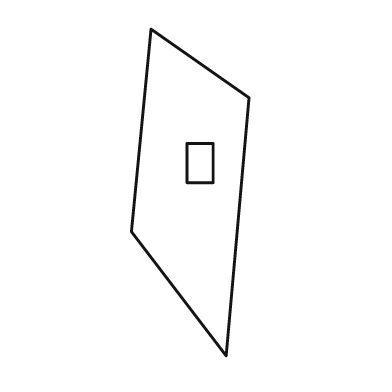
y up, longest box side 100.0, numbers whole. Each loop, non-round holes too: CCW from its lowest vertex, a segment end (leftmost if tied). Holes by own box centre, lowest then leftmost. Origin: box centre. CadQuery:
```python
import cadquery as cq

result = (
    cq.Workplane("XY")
    .moveTo(11.0, -50.0)
    .lineTo(18.0, 29.0)
    .lineTo(-12.0, 50.0)
    .lineTo(-18.0, -12.0)
    .close()
    .moveTo(-1.0, 3.0)
    .lineTo(7.0, 3.0)
    .lineTo(7.0, 15.0)
    .lineTo(-1.0, 15.0)
    .close()
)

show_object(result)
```